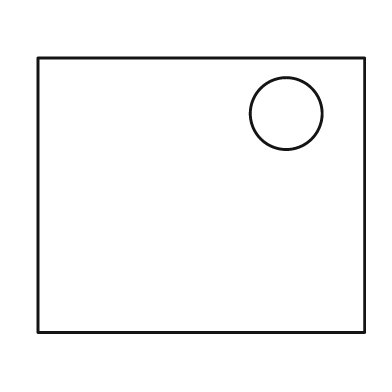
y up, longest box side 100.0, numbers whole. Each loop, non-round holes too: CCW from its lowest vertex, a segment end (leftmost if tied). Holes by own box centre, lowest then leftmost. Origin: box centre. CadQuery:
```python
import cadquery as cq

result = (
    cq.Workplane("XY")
    .moveTo(-50.0, -42.0)
    .lineTo(50.0, -42.0)
    .lineTo(50.0, 42.0)
    .lineTo(-50.0, 42.0)
    .close()
    .moveTo(26.0, 25.0)
    .circle(11.0)
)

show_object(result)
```